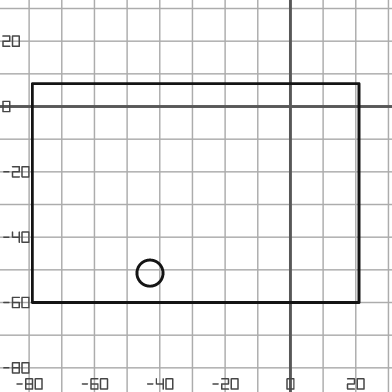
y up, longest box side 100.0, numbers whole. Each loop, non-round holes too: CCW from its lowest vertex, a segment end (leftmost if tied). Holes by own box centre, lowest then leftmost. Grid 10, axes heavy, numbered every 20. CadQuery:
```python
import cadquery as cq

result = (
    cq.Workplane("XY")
    .moveTo(-79.0, -60.0)
    .lineTo(21.0, -60.0)
    .lineTo(21.0, 7.0)
    .lineTo(-79.0, 7.0)
    .close()
    .moveTo(-43.0, -51.0)
    .circle(4.0)
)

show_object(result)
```